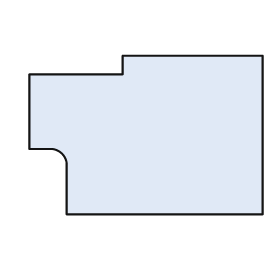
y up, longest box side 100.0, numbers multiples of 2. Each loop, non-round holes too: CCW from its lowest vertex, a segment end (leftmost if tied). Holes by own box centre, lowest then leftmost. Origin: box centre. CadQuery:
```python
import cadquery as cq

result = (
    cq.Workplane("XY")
    .moveTo(-34.0, -34.0)
    .lineTo(50.0, -34.0)
    .lineTo(50.0, 34.0)
    .lineTo(-10.0, 34.0)
    .lineTo(-10.0, 26.0)
    .lineTo(-50.0, 26.0)
    .lineTo(-50.0, -6.0)
    .lineTo(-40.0, -6.0)
    .threePointArc((-36.0, -8.0), (-34.0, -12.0))
    .close()
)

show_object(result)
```